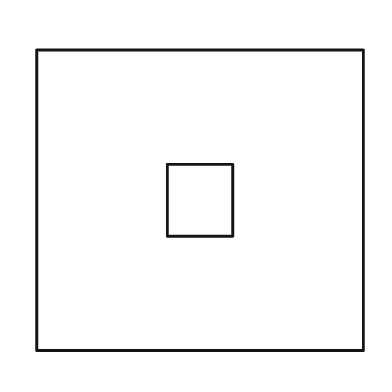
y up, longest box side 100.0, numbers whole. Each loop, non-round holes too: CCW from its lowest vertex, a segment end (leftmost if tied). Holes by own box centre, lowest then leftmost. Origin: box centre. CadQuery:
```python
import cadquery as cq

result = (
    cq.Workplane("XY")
    .moveTo(-50.0, -46.0)
    .lineTo(50.0, -46.0)
    .lineTo(50.0, 46.0)
    .lineTo(-50.0, 46.0)
    .close()
    .moveTo(-10.0, -11.0)
    .lineTo(10.0, -11.0)
    .lineTo(10.0, 11.0)
    .lineTo(-10.0, 11.0)
    .close()
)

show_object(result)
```